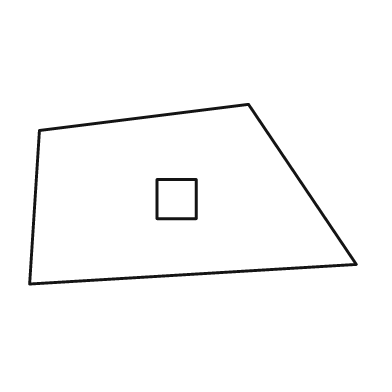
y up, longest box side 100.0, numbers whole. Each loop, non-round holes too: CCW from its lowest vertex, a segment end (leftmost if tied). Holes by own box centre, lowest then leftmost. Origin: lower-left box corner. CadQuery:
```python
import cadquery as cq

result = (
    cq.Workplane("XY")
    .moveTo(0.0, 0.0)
    .lineTo(100.0, 6.0)
    .lineTo(67.0, 55.0)
    .lineTo(3.0, 47.0)
    .close()
    .moveTo(39.0, 20.0)
    .lineTo(51.0, 20.0)
    .lineTo(51.0, 32.0)
    .lineTo(39.0, 32.0)
    .close()
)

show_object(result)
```